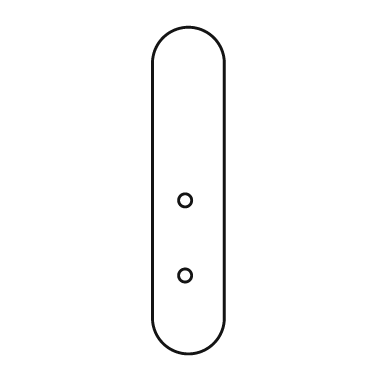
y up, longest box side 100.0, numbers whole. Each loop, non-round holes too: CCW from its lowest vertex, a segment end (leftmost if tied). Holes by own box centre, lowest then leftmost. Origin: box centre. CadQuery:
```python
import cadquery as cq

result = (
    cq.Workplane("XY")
    .moveTo(-11.0, -39.0)
    .threePointArc((0.0, -50.0), (11.0, -39.0))
    .lineTo(11.0, 39.0)
    .threePointArc((0.0, 50.0), (-11.0, 39.0))
    .close()
    .moveTo(-1.0, -26.0)
    .circle(2.0)
    .moveTo(-1.0, -3.0)
    .circle(2.0)
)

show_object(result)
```